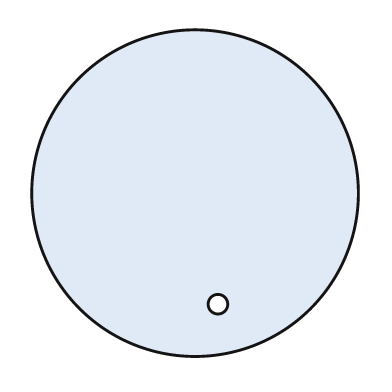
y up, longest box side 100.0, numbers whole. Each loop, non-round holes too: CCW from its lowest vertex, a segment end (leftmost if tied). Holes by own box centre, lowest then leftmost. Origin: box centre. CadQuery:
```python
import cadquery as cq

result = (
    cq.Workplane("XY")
    .moveTo(0.0, 0.0)
    .circle(50.0)
    .moveTo(7.0, -34.0)
    .circle(3.0)
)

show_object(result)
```